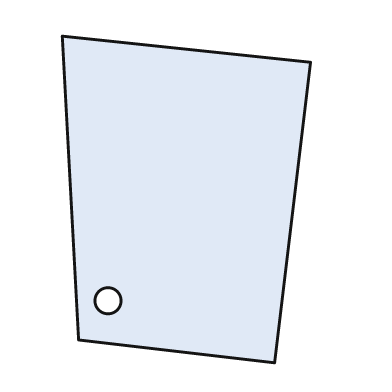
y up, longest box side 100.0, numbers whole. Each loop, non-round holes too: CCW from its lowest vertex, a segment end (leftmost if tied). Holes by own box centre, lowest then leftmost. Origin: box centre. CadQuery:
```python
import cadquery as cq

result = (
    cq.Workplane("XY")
    .moveTo(27.0, -50.0)
    .lineTo(38.0, 42.0)
    .lineTo(-38.0, 50.0)
    .lineTo(-33.0, -43.0)
    .close()
    .moveTo(-24.0, -31.0)
    .circle(4.0)
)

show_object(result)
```